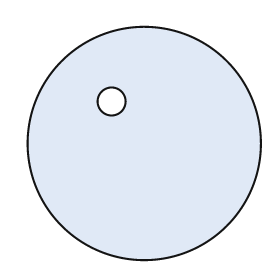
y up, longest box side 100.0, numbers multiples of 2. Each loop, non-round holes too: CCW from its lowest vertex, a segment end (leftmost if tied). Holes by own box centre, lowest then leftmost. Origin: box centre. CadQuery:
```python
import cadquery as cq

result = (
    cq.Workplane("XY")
    .moveTo(0.0, 0.0)
    .circle(50.0)
    .moveTo(-14.0, 18.0)
    .circle(6.0)
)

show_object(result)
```